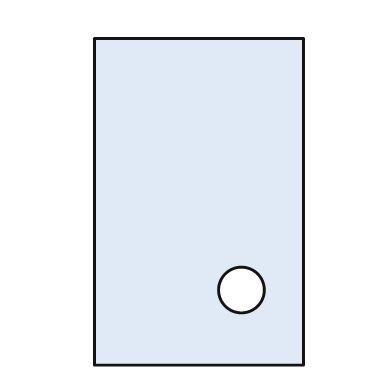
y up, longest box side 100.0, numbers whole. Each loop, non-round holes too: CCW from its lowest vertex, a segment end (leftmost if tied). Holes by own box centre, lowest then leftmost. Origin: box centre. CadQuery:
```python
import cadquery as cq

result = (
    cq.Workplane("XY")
    .moveTo(-32.0, -50.0)
    .lineTo(32.0, -50.0)
    .lineTo(32.0, 50.0)
    .lineTo(-32.0, 50.0)
    .close()
    .moveTo(13.0, -27.0)
    .circle(7.0)
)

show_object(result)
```